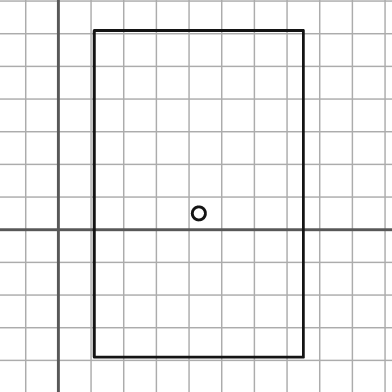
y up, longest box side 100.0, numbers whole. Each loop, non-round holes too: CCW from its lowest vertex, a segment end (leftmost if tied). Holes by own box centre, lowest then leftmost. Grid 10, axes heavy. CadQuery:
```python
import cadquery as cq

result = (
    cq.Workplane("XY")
    .moveTo(11.0, -39.0)
    .lineTo(75.0, -39.0)
    .lineTo(75.0, 61.0)
    .lineTo(11.0, 61.0)
    .close()
    .moveTo(43.0, 5.0)
    .circle(2.0)
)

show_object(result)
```